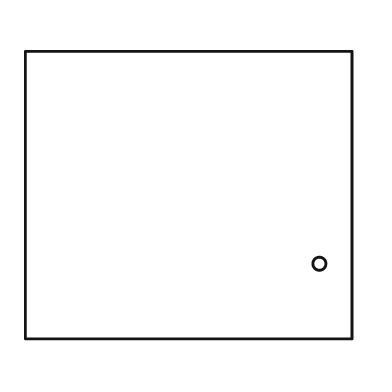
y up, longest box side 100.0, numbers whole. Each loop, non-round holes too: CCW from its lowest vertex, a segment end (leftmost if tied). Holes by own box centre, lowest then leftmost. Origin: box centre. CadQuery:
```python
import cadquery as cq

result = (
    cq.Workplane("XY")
    .moveTo(-50.0, -44.0)
    .lineTo(50.0, -44.0)
    .lineTo(50.0, 44.0)
    .lineTo(-50.0, 44.0)
    .close()
    .moveTo(40.0, -21.0)
    .circle(2.0)
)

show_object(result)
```